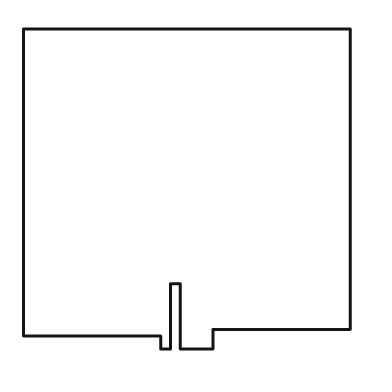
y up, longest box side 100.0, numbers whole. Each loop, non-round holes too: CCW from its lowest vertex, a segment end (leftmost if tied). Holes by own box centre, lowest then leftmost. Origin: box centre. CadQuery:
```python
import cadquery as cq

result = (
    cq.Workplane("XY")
    .moveTo(-8.0, -49.0)
    .lineTo(-5.0, -49.0)
    .lineTo(-5.0, -29.0)
    .lineTo(-2.0, -29.0)
    .lineTo(-2.0, -49.0)
    .lineTo(8.0, -49.0)
    .lineTo(8.0, -43.0)
    .lineTo(50.0, -43.0)
    .lineTo(50.0, 49.0)
    .lineTo(-50.0, 49.0)
    .lineTo(-50.0, -45.0)
    .lineTo(-8.0, -45.0)
    .close()
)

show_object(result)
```